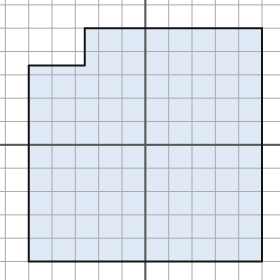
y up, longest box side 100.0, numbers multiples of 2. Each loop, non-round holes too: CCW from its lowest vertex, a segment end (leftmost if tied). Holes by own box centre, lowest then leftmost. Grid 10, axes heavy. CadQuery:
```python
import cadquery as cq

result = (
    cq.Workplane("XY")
    .moveTo(-50.0, -50.0)
    .lineTo(50.0, -50.0)
    .lineTo(50.0, 50.0)
    .lineTo(-26.0, 50.0)
    .lineTo(-26.0, 34.0)
    .lineTo(-50.0, 34.0)
    .close()
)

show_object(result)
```